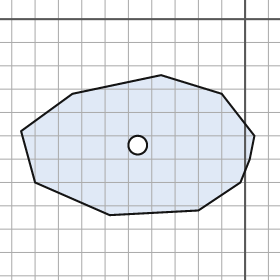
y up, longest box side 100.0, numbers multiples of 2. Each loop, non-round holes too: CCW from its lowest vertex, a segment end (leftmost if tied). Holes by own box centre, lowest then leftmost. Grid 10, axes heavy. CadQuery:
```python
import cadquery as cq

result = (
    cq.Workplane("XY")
    .moveTo(-58.0, -84.0)
    .lineTo(-20.0, -82.0)
    .lineTo(-2.0, -70.0)
    .lineTo(2.0, -60.0)
    .lineTo(4.0, -50.0)
    .lineTo(-10.0, -32.0)
    .lineTo(-36.0, -24.0)
    .lineTo(-74.0, -32.0)
    .lineTo(-96.0, -48.0)
    .lineTo(-90.0, -70.0)
    .close()
    .moveTo(-46.0, -54.0)
    .circle(4.0)
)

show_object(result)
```